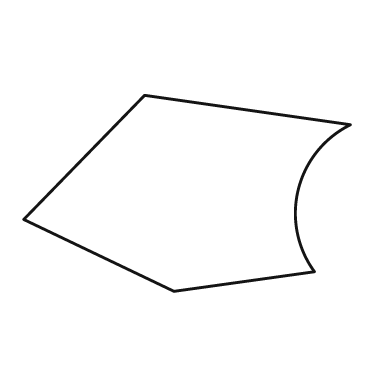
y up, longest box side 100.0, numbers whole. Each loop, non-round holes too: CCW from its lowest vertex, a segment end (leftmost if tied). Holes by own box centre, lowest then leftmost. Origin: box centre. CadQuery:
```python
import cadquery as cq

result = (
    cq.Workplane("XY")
    .moveTo(-4.0, -30.0)
    .lineTo(39.0, -24.0)
    .threePointArc((34.0, 1.0), (50.0, 21.0))
    .lineTo(-13.0, 30.0)
    .lineTo(-50.0, -8.0)
    .close()
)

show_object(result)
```